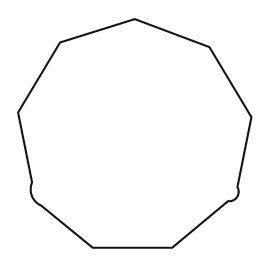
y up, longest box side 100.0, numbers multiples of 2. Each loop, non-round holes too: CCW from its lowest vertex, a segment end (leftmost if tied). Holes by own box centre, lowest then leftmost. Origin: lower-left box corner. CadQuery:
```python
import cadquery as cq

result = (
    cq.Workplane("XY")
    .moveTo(32.0, 0.0)
    .lineTo(66.0, 0.0)
    .lineTo(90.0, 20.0)
    .threePointArc((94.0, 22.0), (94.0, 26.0))
    .lineTo(100.0, 56.0)
    .lineTo(82.0, 86.0)
    .lineTo(50.0, 98.0)
    .lineTo(18.0, 88.0)
    .lineTo(0.0, 58.0)
    .lineTo(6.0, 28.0)
    .threePointArc((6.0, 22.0), (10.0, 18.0))
    .close()
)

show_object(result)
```